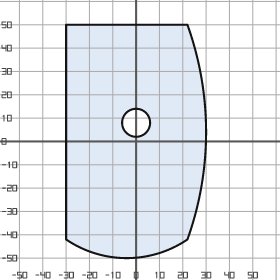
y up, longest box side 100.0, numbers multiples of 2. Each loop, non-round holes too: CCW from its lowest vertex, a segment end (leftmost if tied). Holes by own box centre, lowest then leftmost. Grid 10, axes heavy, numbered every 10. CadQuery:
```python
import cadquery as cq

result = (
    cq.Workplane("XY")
    .moveTo(-30.0, -42.0)
    .threePointArc((-4.0, -50.0), (22.0, -42.0))
    .threePointArc((30.0, 4.0), (22.0, 50.0))
    .lineTo(-30.0, 50.0)
    .close()
    .moveTo(0.0, 8.0)
    .circle(6.0)
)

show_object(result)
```